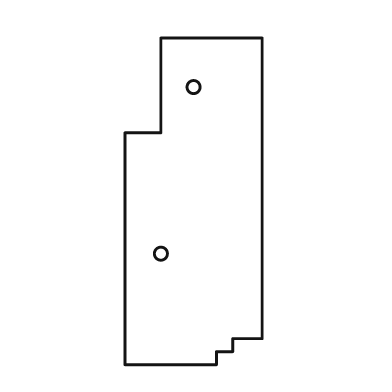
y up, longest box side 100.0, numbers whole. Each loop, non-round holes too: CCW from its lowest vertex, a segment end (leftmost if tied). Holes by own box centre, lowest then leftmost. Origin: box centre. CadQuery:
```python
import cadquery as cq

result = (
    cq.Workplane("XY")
    .moveTo(-21.0, -50.0)
    .lineTo(7.0, -50.0)
    .lineTo(7.0, -46.0)
    .lineTo(12.0, -46.0)
    .lineTo(12.0, -42.0)
    .lineTo(21.0, -42.0)
    .lineTo(21.0, 50.0)
    .lineTo(-10.0, 50.0)
    .lineTo(-10.0, 21.0)
    .lineTo(-21.0, 21.0)
    .close()
    .moveTo(-10.0, -16.0)
    .circle(2.0)
    .moveTo(0.0, 35.0)
    .circle(2.0)
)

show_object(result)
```